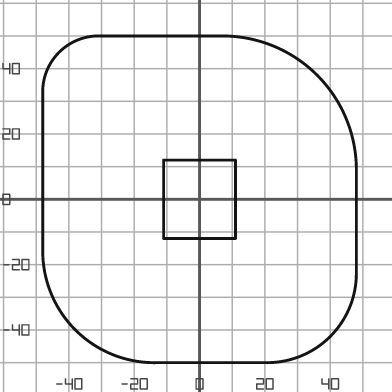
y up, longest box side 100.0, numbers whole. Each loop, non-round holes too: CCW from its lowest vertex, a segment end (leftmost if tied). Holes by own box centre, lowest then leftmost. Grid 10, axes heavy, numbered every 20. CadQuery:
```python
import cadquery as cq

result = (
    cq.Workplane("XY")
    .moveTo(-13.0, -50.0)
    .lineTo(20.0, -50.0)
    .threePointArc((40.0, -42.0), (48.0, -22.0))
    .lineTo(48.0, 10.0)
    .threePointArc((36.0, 38.0), (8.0, 50.0))
    .lineTo(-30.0, 50.0)
    .threePointArc((-43.0, 45.0), (-48.0, 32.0))
    .lineTo(-48.0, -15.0)
    .threePointArc((-38.0, -40.0), (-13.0, -50.0))
    .close()
    .moveTo(-11.0, -12.0)
    .lineTo(11.0, -12.0)
    .lineTo(11.0, 12.0)
    .lineTo(-11.0, 12.0)
    .close()
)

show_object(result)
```